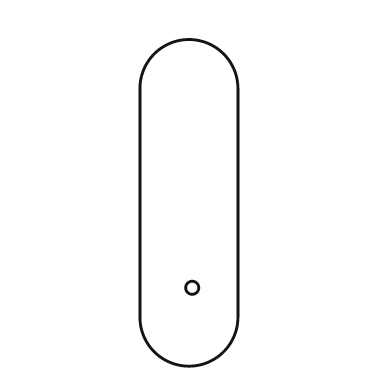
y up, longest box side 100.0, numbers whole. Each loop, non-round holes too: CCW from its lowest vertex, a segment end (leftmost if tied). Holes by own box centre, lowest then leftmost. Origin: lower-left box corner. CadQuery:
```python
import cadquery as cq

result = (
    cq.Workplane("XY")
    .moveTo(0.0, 15.0)
    .threePointArc((15.0, 0.0), (30.0, 15.0))
    .lineTo(30.0, 85.0)
    .threePointArc((15.0, 100.0), (0.0, 85.0))
    .close()
    .moveTo(16.0, 24.0)
    .circle(2.0)
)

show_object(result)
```